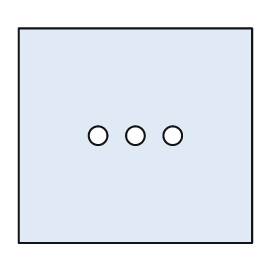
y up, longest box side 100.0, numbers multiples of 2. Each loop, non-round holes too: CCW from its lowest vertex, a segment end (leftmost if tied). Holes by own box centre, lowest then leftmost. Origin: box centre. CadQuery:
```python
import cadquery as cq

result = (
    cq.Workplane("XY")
    .moveTo(-50.0, -46.0)
    .lineTo(50.0, -46.0)
    .lineTo(50.0, 46.0)
    .lineTo(-50.0, 46.0)
    .close()
    .moveTo(-16.0, 0.0)
    .circle(4.0)
    .moveTo(0.0, 0.0)
    .circle(4.0)
    .moveTo(16.0, 0.0)
    .circle(4.0)
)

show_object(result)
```